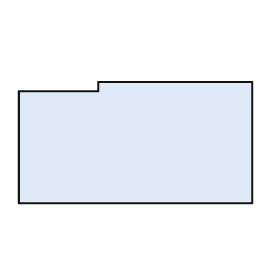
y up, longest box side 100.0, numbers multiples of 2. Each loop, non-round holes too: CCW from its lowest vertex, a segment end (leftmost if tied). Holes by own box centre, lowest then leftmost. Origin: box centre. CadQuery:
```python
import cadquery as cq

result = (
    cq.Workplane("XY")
    .moveTo(-50.0, -26.0)
    .lineTo(50.0, -26.0)
    .lineTo(50.0, 26.0)
    .lineTo(-16.0, 26.0)
    .lineTo(-16.0, 22.0)
    .lineTo(-50.0, 22.0)
    .close()
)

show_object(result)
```